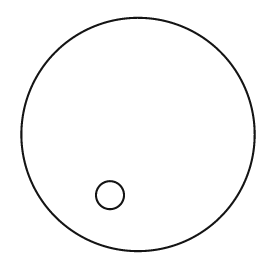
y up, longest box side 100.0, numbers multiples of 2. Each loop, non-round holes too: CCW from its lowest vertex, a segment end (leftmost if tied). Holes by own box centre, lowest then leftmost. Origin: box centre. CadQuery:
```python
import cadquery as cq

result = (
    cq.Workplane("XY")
    .moveTo(0.0, 0.0)
    .circle(50.0)
    .moveTo(-12.0, -26.0)
    .circle(6.0)
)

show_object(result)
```